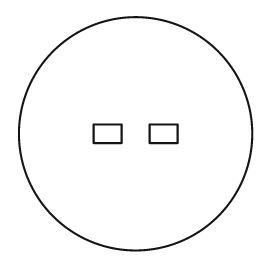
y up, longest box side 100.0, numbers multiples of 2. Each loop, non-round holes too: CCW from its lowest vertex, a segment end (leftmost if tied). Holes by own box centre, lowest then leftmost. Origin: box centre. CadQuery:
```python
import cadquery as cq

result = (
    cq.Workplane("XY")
    .moveTo(0.0, 0.0)
    .circle(50.0)
    .moveTo(-18.0, -4.0)
    .lineTo(-6.0, -4.0)
    .lineTo(-6.0, 4.0)
    .lineTo(-18.0, 4.0)
    .close()
    .moveTo(6.0, -4.0)
    .lineTo(18.0, -4.0)
    .lineTo(18.0, 4.0)
    .lineTo(6.0, 4.0)
    .close()
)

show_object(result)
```